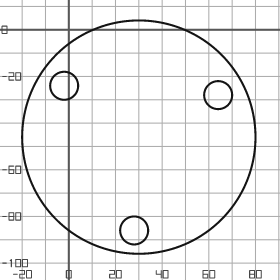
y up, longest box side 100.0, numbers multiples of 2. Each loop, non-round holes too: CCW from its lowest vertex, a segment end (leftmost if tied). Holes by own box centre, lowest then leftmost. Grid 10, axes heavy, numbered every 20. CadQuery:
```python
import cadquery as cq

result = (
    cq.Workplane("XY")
    .moveTo(30.0, -46.0)
    .circle(50.0)
    .moveTo(28.0, -86.0)
    .circle(6.0)
    .moveTo(64.0, -28.0)
    .circle(6.0)
    .moveTo(-2.0, -24.0)
    .circle(6.0)
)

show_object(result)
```